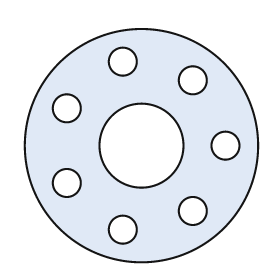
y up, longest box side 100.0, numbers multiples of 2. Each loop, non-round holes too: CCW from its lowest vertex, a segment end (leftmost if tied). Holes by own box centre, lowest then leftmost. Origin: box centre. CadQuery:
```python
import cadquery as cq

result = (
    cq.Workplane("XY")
    .moveTo(0.0, 0.0)
    .circle(50.0)
    .moveTo(-8.0, -36.0)
    .circle(6.0)
    .moveTo(22.0, -28.0)
    .circle(6.0)
    .moveTo(-32.0, -16.0)
    .circle(6.0)
    .moveTo(0.0, 0.0)
    .circle(18.0)
    .moveTo(36.0, 0.0)
    .circle(6.0)
    .moveTo(-32.0, 16.0)
    .circle(6.0)
    .moveTo(22.0, 28.0)
    .circle(6.0)
    .moveTo(-8.0, 36.0)
    .circle(6.0)
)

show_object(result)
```